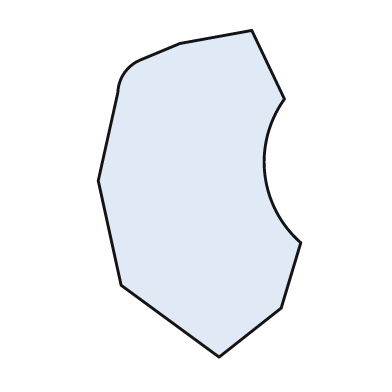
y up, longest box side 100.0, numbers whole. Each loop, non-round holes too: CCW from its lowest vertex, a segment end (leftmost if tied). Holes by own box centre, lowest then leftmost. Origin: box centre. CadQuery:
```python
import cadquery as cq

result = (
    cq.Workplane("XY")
    .moveTo(6.0, -50.0)
    .lineTo(25.0, -35.0)
    .lineTo(31.0, -15.0)
    .threePointArc((20.0, 6.0), (26.0, 29.0))
    .lineTo(16.0, 50.0)
    .lineTo(-6.0, 46.0)
    .lineTo(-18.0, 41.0)
    .threePointArc((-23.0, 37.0), (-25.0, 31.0))
    .lineTo(-31.0, 4.0)
    .lineTo(-24.0, -28.0)
    .close()
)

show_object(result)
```